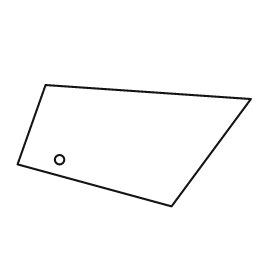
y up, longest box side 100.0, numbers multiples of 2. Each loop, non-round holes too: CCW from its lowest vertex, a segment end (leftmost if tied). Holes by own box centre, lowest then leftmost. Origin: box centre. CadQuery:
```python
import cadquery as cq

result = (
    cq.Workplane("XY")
    .moveTo(16.0, -26.0)
    .lineTo(50.0, 20.0)
    .lineTo(-38.0, 26.0)
    .lineTo(-50.0, -8.0)
    .close()
    .moveTo(-32.0, -6.0)
    .circle(2.0)
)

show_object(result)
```